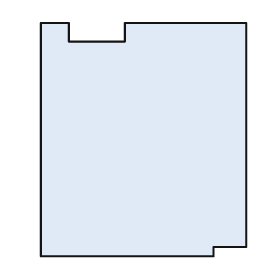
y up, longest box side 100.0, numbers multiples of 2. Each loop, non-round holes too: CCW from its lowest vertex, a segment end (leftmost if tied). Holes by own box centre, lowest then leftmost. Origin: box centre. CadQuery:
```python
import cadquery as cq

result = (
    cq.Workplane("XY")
    .moveTo(-44.0, -50.0)
    .lineTo(30.0, -50.0)
    .lineTo(30.0, -46.0)
    .lineTo(44.0, -46.0)
    .lineTo(44.0, 50.0)
    .lineTo(-8.0, 50.0)
    .lineTo(-8.0, 42.0)
    .lineTo(-32.0, 42.0)
    .lineTo(-32.0, 50.0)
    .lineTo(-44.0, 50.0)
    .close()
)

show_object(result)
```